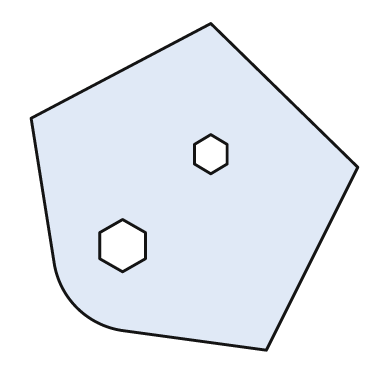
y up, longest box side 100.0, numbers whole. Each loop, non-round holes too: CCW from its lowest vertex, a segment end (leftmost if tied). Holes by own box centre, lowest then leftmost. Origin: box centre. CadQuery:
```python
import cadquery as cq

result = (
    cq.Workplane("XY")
    .moveTo(22.0, -50.0)
    .lineTo(50.0, 6.0)
    .lineTo(5.0, 50.0)
    .lineTo(-50.0, 21.0)
    .lineTo(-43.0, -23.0)
    .threePointArc((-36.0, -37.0), (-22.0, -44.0))
    .close()
    .moveTo(-22.0, -26.0)
    .lineTo(-15.0, -22.0)
    .lineTo(-15.0, -14.0)
    .lineTo(-22.0, -10.0)
    .lineTo(-29.0, -14.0)
    .lineTo(-29.0, -22.0)
    .close()
    .moveTo(5.0, 4.0)
    .lineTo(10.0, 7.0)
    .lineTo(10.0, 13.0)
    .lineTo(5.0, 16.0)
    .lineTo(0.0, 13.0)
    .lineTo(0.0, 7.0)
    .close()
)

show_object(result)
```